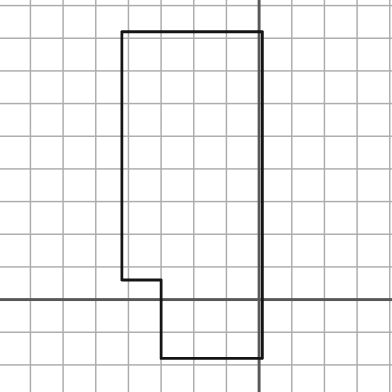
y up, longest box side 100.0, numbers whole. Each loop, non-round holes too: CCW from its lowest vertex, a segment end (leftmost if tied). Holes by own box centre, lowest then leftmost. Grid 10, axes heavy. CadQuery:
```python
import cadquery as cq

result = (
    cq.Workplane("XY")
    .moveTo(-30.0, -18.0)
    .lineTo(1.0, -18.0)
    .lineTo(1.0, 82.0)
    .lineTo(-42.0, 82.0)
    .lineTo(-42.0, 6.0)
    .lineTo(-30.0, 6.0)
    .close()
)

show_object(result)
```